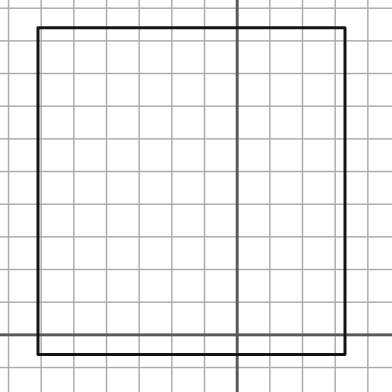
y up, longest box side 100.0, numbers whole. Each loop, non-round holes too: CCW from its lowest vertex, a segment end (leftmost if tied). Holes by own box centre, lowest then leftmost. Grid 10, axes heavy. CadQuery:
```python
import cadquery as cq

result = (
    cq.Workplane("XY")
    .moveTo(-61.0, -6.0)
    .lineTo(33.0, -6.0)
    .lineTo(33.0, 94.0)
    .lineTo(-61.0, 94.0)
    .close()
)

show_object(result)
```